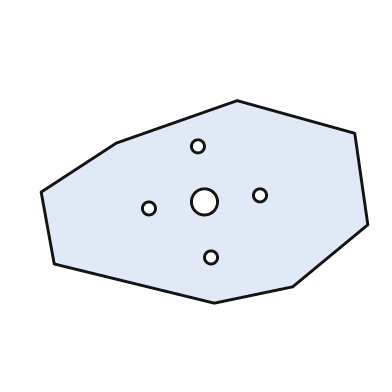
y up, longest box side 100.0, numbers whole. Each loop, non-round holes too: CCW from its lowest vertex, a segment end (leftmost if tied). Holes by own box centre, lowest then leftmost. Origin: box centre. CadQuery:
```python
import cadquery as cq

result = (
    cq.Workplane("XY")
    .moveTo(3.0, -31.0)
    .lineTo(27.0, -26.0)
    .lineTo(50.0, -7.0)
    .lineTo(46.0, 21.0)
    .lineTo(10.0, 31.0)
    .lineTo(-27.0, 18.0)
    .lineTo(-50.0, 3.0)
    .lineTo(-46.0, -19.0)
    .close()
    .moveTo(2.0, -17.0)
    .circle(2.0)
    .moveTo(-17.0, -2.0)
    .circle(2.0)
    .moveTo(0.0, 0.0)
    .circle(4.0)
    .moveTo(17.0, 2.0)
    .circle(2.0)
    .moveTo(-2.0, 17.0)
    .circle(2.0)
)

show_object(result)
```